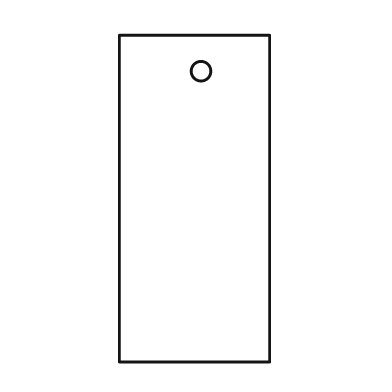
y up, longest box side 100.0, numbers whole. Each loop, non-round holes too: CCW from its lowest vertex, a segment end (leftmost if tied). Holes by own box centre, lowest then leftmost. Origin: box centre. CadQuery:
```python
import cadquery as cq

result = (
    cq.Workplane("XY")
    .moveTo(-23.0, -50.0)
    .lineTo(23.0, -50.0)
    .lineTo(23.0, 50.0)
    .lineTo(-23.0, 50.0)
    .close()
    .moveTo(2.0, 39.0)
    .circle(3.0)
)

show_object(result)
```